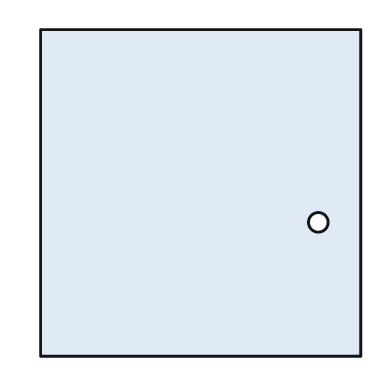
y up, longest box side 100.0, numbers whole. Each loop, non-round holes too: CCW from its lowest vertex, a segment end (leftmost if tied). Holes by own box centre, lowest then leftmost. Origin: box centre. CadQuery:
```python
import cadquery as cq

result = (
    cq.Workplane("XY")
    .moveTo(-49.0, -50.0)
    .lineTo(49.0, -50.0)
    .lineTo(49.0, 50.0)
    .lineTo(-49.0, 50.0)
    .close()
    .moveTo(36.0, -9.0)
    .circle(3.0)
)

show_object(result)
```